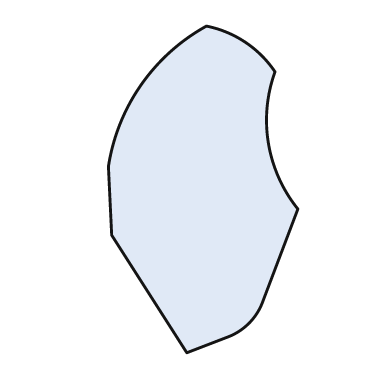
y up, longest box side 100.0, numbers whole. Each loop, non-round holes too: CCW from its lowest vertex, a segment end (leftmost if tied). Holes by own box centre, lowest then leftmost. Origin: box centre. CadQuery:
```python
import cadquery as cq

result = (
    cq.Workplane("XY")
    .moveTo(-5.0, -50.0)
    .lineTo(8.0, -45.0)
    .threePointArc((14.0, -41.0), (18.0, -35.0))
    .lineTo(29.0, -6.0)
    .threePointArc((20.0, 14.0), (22.0, 36.0))
    .threePointArc((13.0, 45.0), (1.0, 50.0))
    .threePointArc((-19.0, 32.0), (-29.0, 7.0))
    .lineTo(-28.0, -14.0)
    .close()
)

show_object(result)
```